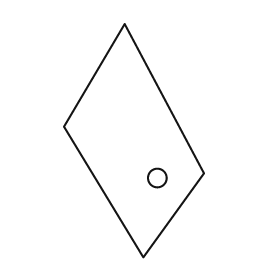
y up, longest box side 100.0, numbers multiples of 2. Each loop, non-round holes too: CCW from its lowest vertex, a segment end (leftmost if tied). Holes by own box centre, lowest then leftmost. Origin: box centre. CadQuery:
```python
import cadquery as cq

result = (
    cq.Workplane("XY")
    .moveTo(4.0, -50.0)
    .lineTo(30.0, -14.0)
    .lineTo(-4.0, 50.0)
    .lineTo(-30.0, 6.0)
    .close()
    .moveTo(10.0, -16.0)
    .circle(4.0)
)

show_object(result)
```